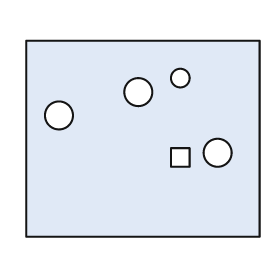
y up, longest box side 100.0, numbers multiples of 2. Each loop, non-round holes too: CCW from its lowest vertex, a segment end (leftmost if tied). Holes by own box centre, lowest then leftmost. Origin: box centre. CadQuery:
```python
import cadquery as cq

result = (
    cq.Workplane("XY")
    .moveTo(-50.0, -42.0)
    .lineTo(50.0, -42.0)
    .lineTo(50.0, 42.0)
    .lineTo(-50.0, 42.0)
    .close()
    .moveTo(12.0, -12.0)
    .lineTo(20.0, -12.0)
    .lineTo(20.0, -4.0)
    .lineTo(12.0, -4.0)
    .close()
    .moveTo(32.0, -6.0)
    .circle(6.0)
    .moveTo(-36.0, 10.0)
    .circle(6.0)
    .moveTo(-2.0, 20.0)
    .circle(6.0)
    .moveTo(16.0, 26.0)
    .circle(4.0)
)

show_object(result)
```